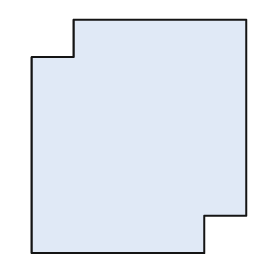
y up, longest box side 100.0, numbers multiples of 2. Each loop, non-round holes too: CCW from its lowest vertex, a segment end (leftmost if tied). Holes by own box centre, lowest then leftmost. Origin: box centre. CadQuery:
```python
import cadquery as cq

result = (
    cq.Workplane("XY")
    .moveTo(-46.0, -50.0)
    .lineTo(28.0, -50.0)
    .lineTo(28.0, -34.0)
    .lineTo(46.0, -34.0)
    .lineTo(46.0, 50.0)
    .lineTo(-28.0, 50.0)
    .lineTo(-28.0, 34.0)
    .lineTo(-46.0, 34.0)
    .close()
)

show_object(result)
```